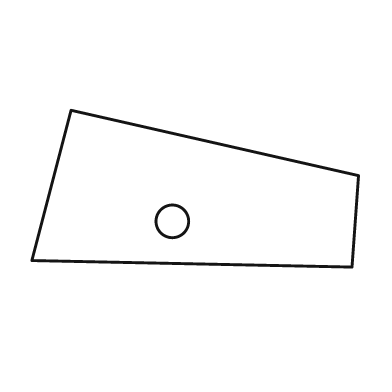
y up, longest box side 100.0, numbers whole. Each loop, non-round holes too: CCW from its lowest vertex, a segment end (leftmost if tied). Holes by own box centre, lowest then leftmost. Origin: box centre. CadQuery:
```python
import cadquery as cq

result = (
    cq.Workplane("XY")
    .moveTo(48.0, -24.0)
    .lineTo(50.0, 4.0)
    .lineTo(-38.0, 24.0)
    .lineTo(-50.0, -22.0)
    .close()
    .moveTo(-7.0, -10.0)
    .circle(5.0)
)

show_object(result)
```